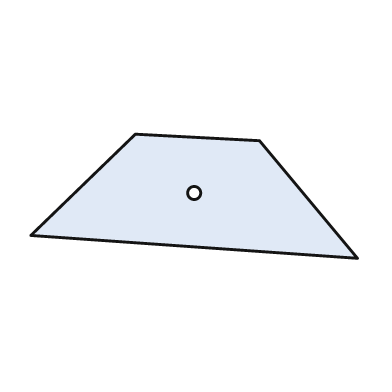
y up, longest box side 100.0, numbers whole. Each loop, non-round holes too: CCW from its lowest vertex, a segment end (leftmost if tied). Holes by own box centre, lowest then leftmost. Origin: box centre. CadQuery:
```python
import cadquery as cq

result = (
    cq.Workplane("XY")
    .moveTo(50.0, -19.0)
    .lineTo(20.0, 17.0)
    .lineTo(-18.0, 19.0)
    .lineTo(-50.0, -12.0)
    .close()
    .moveTo(0.0, 1.0)
    .circle(2.0)
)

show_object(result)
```